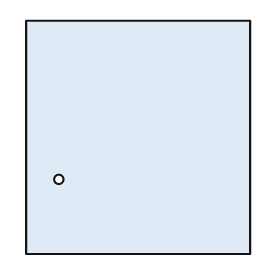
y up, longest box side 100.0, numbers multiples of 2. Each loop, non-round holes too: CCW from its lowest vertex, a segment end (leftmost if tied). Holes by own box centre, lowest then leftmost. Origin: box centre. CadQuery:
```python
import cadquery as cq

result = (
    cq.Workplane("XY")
    .moveTo(-48.0, -50.0)
    .lineTo(48.0, -50.0)
    .lineTo(48.0, 50.0)
    .lineTo(-48.0, 50.0)
    .close()
    .moveTo(-34.0, -18.0)
    .circle(2.0)
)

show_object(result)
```